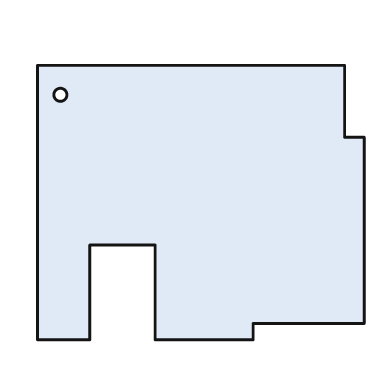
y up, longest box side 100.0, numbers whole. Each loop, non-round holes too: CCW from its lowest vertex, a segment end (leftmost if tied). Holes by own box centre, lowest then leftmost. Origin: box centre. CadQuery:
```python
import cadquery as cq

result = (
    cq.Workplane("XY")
    .moveTo(-50.0, -42.0)
    .lineTo(-34.0, -42.0)
    .lineTo(-34.0, -13.0)
    .lineTo(-14.0, -13.0)
    .lineTo(-14.0, -42.0)
    .lineTo(16.0, -42.0)
    .lineTo(16.0, -37.0)
    .lineTo(50.0, -37.0)
    .lineTo(50.0, 20.0)
    .lineTo(44.0, 20.0)
    .lineTo(44.0, 42.0)
    .lineTo(-50.0, 42.0)
    .close()
    .moveTo(-43.0, 33.0)
    .circle(2.0)
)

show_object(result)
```